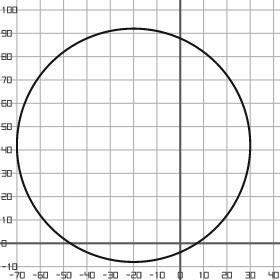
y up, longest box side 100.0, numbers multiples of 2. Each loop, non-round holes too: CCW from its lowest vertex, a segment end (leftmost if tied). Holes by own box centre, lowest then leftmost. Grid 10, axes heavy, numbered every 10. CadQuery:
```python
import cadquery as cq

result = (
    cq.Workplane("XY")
    .moveTo(-20.0, 42.0)
    .circle(50.0)
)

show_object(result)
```